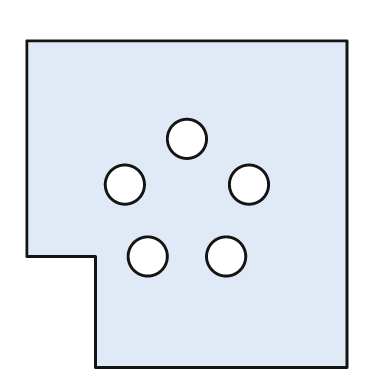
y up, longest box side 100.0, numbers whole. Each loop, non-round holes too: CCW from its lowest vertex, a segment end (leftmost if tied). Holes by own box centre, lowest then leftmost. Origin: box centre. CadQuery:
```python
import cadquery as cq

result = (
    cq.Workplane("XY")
    .moveTo(-28.0, -50.0)
    .lineTo(49.0, -50.0)
    .lineTo(49.0, 50.0)
    .lineTo(-49.0, 50.0)
    .lineTo(-49.0, -16.0)
    .lineTo(-28.0, -16.0)
    .close()
    .moveTo(-12.0, -16.0)
    .circle(6.0)
    .moveTo(12.0, -16.0)
    .circle(6.0)
    .moveTo(-19.0, 6.0)
    .circle(6.0)
    .moveTo(19.0, 6.0)
    .circle(6.0)
    .moveTo(0.0, 20.0)
    .circle(6.0)
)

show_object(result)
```